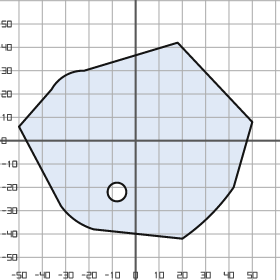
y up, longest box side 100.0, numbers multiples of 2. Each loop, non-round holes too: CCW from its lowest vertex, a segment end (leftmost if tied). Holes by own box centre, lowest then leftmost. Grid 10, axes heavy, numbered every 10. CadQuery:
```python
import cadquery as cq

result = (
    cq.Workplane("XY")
    .moveTo(20.0, -42.0)
    .threePointArc((32.0, -32.0), (42.0, -20.0))
    .lineTo(50.0, 8.0)
    .lineTo(18.0, 42.0)
    .lineTo(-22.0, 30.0)
    .threePointArc((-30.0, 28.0), (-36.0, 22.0))
    .lineTo(-50.0, 6.0)
    .lineTo(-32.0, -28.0)
    .threePointArc((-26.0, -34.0), (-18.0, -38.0))
    .close()
    .moveTo(-8.0, -22.0)
    .circle(4.0)
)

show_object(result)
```